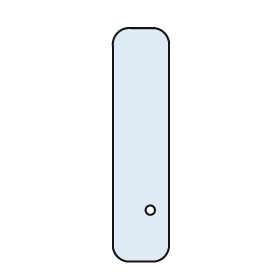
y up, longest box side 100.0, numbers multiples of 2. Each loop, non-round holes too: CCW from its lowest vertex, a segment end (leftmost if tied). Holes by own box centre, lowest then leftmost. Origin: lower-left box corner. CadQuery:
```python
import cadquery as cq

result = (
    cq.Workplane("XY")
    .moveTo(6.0, 0.0)
    .lineTo(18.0, 0.0)
    .threePointArc((22.0, 2.0), (24.0, 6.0))
    .lineTo(24.0, 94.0)
    .threePointArc((22.0, 98.0), (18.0, 100.0))
    .lineTo(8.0, 100.0)
    .threePointArc((2.0, 98.0), (0.0, 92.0))
    .lineTo(0.0, 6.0)
    .threePointArc((2.0, 2.0), (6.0, 0.0))
    .close()
    .moveTo(16.0, 22.0)
    .circle(2.0)
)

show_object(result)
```